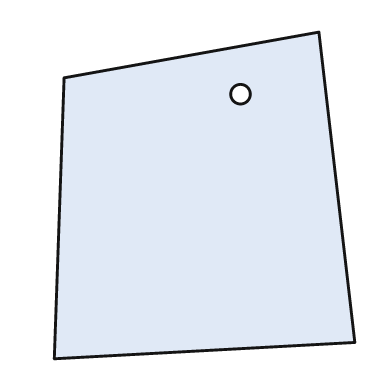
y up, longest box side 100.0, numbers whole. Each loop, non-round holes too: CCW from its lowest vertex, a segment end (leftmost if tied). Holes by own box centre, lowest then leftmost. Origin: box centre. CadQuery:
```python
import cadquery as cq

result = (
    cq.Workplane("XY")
    .moveTo(-46.0, -50.0)
    .lineTo(46.0, -45.0)
    .lineTo(35.0, 50.0)
    .lineTo(-43.0, 36.0)
    .close()
    .moveTo(11.0, 31.0)
    .circle(3.0)
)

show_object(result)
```